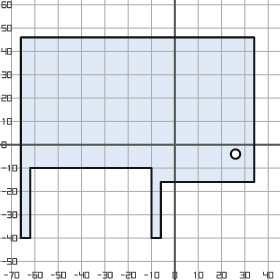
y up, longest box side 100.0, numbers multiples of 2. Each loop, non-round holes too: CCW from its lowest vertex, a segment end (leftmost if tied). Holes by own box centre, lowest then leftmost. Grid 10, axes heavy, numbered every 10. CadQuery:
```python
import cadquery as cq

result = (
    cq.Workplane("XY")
    .moveTo(-66.0, -40.0)
    .lineTo(-62.0, -40.0)
    .lineTo(-62.0, -10.0)
    .lineTo(-10.0, -10.0)
    .lineTo(-10.0, -40.0)
    .lineTo(-6.0, -40.0)
    .lineTo(-6.0, -16.0)
    .lineTo(34.0, -16.0)
    .lineTo(34.0, 46.0)
    .lineTo(-66.0, 46.0)
    .close()
    .moveTo(26.0, -4.0)
    .circle(2.0)
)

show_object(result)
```